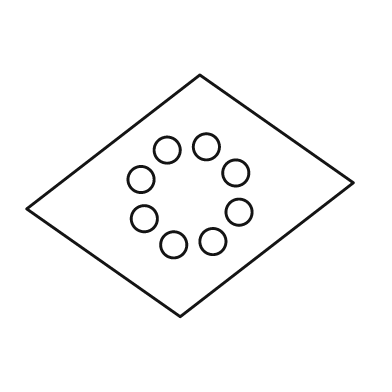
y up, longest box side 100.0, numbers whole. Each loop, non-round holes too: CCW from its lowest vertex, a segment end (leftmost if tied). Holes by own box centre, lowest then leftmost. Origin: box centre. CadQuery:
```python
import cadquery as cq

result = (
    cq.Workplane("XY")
    .moveTo(-3.0, -37.0)
    .lineTo(50.0, 4.0)
    .lineTo(3.0, 37.0)
    .lineTo(-50.0, -4.0)
    .close()
    .moveTo(-5.0, -15.0)
    .circle(4.0)
    .moveTo(7.0, -14.0)
    .circle(4.0)
    .moveTo(-14.0, -7.0)
    .circle(4.0)
    .moveTo(15.0, -5.0)
    .circle(4.0)
    .moveTo(-15.0, 5.0)
    .circle(4.0)
    .moveTo(14.0, 7.0)
    .circle(4.0)
    .moveTo(-7.0, 14.0)
    .circle(4.0)
    .moveTo(5.0, 15.0)
    .circle(4.0)
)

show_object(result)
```